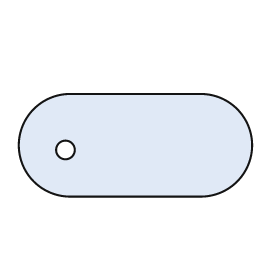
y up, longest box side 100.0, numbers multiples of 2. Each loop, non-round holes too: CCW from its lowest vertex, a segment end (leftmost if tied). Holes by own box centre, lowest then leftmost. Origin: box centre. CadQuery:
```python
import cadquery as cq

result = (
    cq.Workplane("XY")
    .moveTo(-28.0, -22.0)
    .lineTo(28.0, -22.0)
    .threePointArc((50.0, 0.0), (28.0, 22.0))
    .lineTo(-28.0, 22.0)
    .threePointArc((-50.0, 0.0), (-28.0, -22.0))
    .close()
    .moveTo(-30.0, -2.0)
    .circle(4.0)
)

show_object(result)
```